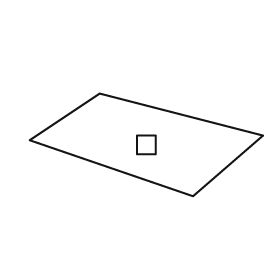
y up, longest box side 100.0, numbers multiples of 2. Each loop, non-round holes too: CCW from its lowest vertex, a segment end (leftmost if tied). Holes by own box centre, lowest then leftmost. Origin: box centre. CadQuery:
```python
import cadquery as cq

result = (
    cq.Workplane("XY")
    .moveTo(20.0, -22.0)
    .lineTo(50.0, 4.0)
    .lineTo(-20.0, 22.0)
    .lineTo(-50.0, 2.0)
    .close()
    .moveTo(-4.0, -4.0)
    .lineTo(4.0, -4.0)
    .lineTo(4.0, 4.0)
    .lineTo(-4.0, 4.0)
    .close()
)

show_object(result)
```